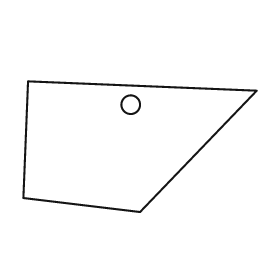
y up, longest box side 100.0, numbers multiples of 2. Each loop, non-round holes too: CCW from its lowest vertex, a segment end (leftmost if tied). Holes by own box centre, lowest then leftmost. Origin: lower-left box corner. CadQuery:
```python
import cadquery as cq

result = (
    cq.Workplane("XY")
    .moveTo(50.0, 0.0)
    .lineTo(100.0, 52.0)
    .lineTo(2.0, 56.0)
    .lineTo(0.0, 6.0)
    .close()
    .moveTo(46.0, 46.0)
    .circle(4.0)
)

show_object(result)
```